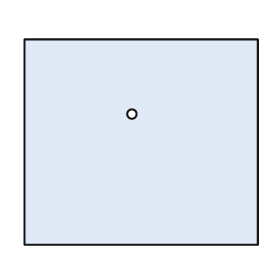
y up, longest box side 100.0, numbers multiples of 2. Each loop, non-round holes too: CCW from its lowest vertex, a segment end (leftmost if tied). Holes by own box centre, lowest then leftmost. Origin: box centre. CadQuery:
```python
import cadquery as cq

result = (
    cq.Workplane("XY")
    .moveTo(-50.0, -44.0)
    .lineTo(50.0, -44.0)
    .lineTo(50.0, 44.0)
    .lineTo(-50.0, 44.0)
    .close()
    .moveTo(-4.0, 12.0)
    .circle(2.0)
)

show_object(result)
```